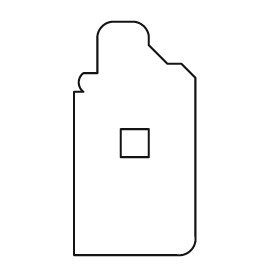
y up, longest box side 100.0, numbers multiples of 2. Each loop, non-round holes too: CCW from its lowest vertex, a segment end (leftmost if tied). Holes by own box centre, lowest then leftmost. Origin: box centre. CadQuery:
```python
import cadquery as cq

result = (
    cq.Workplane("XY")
    .moveTo(-26.0, -50.0)
    .lineTo(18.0, -50.0)
    .threePointArc((24.0, -48.0), (26.0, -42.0))
    .lineTo(26.0, 26.0)
    .lineTo(20.0, 32.0)
    .lineTo(14.0, 32.0)
    .lineTo(6.0, 40.0)
    .lineTo(6.0, 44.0)
    .threePointArc((4.0, 48.0), (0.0, 50.0))
    .lineTo(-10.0, 50.0)
    .threePointArc((-14.0, 48.0), (-16.0, 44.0))
    .lineTo(-16.0, 28.0)
    .lineTo(-22.0, 28.0)
    .threePointArc((-24.0, 24.0), (-22.0, 20.0))
    .lineTo(-26.0, 20.0)
    .close()
    .moveTo(-6.0, -8.0)
    .lineTo(6.0, -8.0)
    .lineTo(6.0, 4.0)
    .lineTo(-6.0, 4.0)
    .close()
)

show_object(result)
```